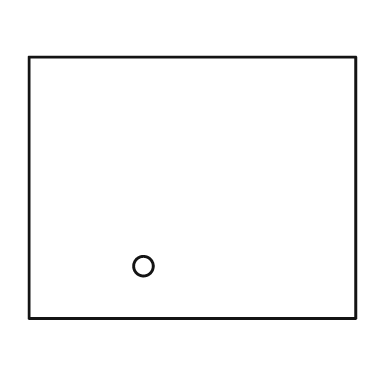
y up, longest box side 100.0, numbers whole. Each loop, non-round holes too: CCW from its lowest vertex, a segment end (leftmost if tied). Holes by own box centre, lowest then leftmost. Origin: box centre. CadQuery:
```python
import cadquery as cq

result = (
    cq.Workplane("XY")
    .moveTo(-50.0, -40.0)
    .lineTo(50.0, -40.0)
    .lineTo(50.0, 40.0)
    .lineTo(-50.0, 40.0)
    .close()
    .moveTo(-15.0, -24.0)
    .circle(3.0)
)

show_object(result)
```